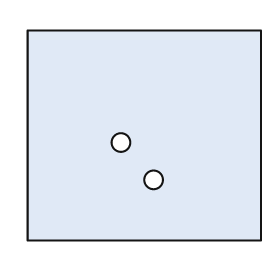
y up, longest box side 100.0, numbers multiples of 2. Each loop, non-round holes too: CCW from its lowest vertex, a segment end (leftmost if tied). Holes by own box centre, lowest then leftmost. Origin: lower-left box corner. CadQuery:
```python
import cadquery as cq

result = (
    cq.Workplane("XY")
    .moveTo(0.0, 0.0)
    .lineTo(100.0, 0.0)
    .lineTo(100.0, 90.0)
    .lineTo(0.0, 90.0)
    .close()
    .moveTo(54.0, 26.0)
    .circle(4.0)
    .moveTo(40.0, 42.0)
    .circle(4.0)
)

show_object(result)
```